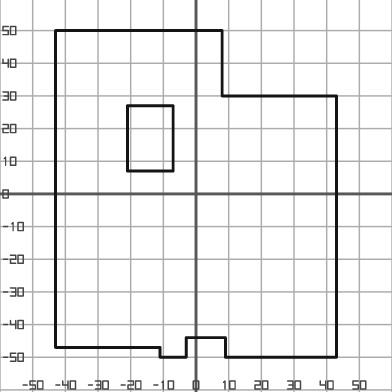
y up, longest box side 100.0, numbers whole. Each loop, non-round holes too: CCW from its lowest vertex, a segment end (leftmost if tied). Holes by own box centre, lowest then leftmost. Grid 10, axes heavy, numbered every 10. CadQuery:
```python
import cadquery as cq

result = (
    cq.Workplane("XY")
    .moveTo(-11.0, -50.0)
    .lineTo(-3.0, -50.0)
    .lineTo(-3.0, -44.0)
    .lineTo(9.0, -44.0)
    .lineTo(9.0, -50.0)
    .lineTo(43.0, -50.0)
    .lineTo(43.0, 30.0)
    .lineTo(8.0, 30.0)
    .lineTo(8.0, 50.0)
    .lineTo(-43.0, 50.0)
    .lineTo(-43.0, -47.0)
    .lineTo(-11.0, -47.0)
    .close()
    .moveTo(-21.0, 7.0)
    .lineTo(-7.0, 7.0)
    .lineTo(-7.0, 27.0)
    .lineTo(-21.0, 27.0)
    .close()
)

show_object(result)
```